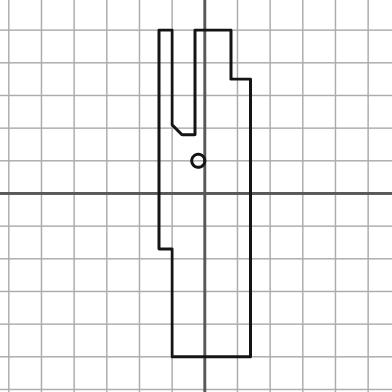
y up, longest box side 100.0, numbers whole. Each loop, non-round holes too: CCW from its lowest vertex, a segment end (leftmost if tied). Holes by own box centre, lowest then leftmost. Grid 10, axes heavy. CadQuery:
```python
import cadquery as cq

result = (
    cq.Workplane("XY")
    .moveTo(-10.0, -50.0)
    .lineTo(14.0, -50.0)
    .lineTo(14.0, 35.0)
    .lineTo(8.0, 35.0)
    .lineTo(8.0, 50.0)
    .lineTo(-3.0, 50.0)
    .lineTo(-3.0, 18.0)
    .lineTo(-7.0, 18.0)
    .lineTo(-10.0, 21.0)
    .lineTo(-10.0, 50.0)
    .lineTo(-14.0, 50.0)
    .lineTo(-14.0, -17.0)
    .lineTo(-10.0, -17.0)
    .close()
    .moveTo(-2.0, 10.0)
    .circle(2.0)
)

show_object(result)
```